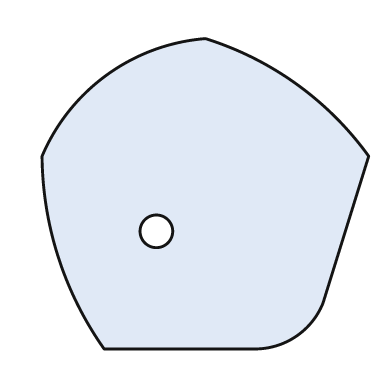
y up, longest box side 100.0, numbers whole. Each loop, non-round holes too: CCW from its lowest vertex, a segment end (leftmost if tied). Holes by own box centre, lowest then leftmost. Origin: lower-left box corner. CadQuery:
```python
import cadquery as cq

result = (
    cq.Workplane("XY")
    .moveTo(19.0, 0.0)
    .lineTo(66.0, 0.0)
    .threePointArc((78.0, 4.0), (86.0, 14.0))
    .lineTo(100.0, 59.0)
    .threePointArc((78.0, 81.0), (50.0, 95.0))
    .threePointArc((20.0, 84.0), (0.0, 59.0))
    .threePointArc((5.0, 28.0), (19.0, 0.0))
    .close()
    .moveTo(35.0, 36.0)
    .circle(5.0)
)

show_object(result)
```